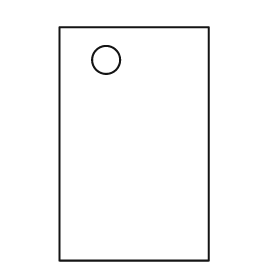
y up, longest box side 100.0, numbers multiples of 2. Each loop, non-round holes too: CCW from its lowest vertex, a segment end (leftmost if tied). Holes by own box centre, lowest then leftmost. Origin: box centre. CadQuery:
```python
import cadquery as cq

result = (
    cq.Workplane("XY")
    .moveTo(-32.0, -50.0)
    .lineTo(32.0, -50.0)
    .lineTo(32.0, 50.0)
    .lineTo(-32.0, 50.0)
    .close()
    .moveTo(-12.0, 36.0)
    .circle(6.0)
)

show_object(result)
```